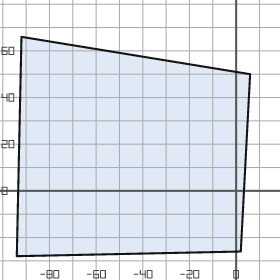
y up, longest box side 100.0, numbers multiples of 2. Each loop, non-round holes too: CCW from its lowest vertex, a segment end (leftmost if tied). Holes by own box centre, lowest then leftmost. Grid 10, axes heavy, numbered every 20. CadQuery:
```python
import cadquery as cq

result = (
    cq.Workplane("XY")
    .moveTo(-94.0, -28.0)
    .lineTo(2.0, -26.0)
    .lineTo(6.0, 50.0)
    .lineTo(-92.0, 66.0)
    .close()
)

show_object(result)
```